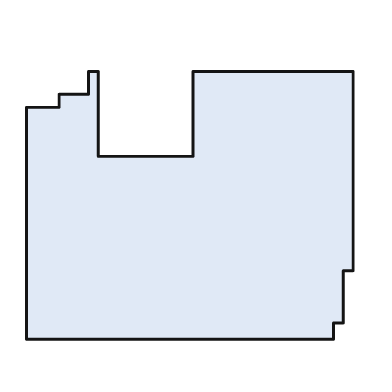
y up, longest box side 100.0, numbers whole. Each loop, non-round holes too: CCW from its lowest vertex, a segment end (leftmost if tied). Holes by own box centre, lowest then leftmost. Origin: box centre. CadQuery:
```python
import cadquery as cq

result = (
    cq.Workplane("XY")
    .moveTo(-50.0, -41.0)
    .lineTo(44.0, -41.0)
    .lineTo(44.0, -36.0)
    .lineTo(47.0, -36.0)
    .lineTo(47.0, -20.0)
    .lineTo(50.0, -20.0)
    .lineTo(50.0, 41.0)
    .lineTo(1.0, 41.0)
    .lineTo(1.0, 15.0)
    .lineTo(-28.0, 15.0)
    .lineTo(-28.0, 41.0)
    .lineTo(-31.0, 41.0)
    .lineTo(-31.0, 34.0)
    .lineTo(-40.0, 34.0)
    .lineTo(-40.0, 30.0)
    .lineTo(-50.0, 30.0)
    .close()
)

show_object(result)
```